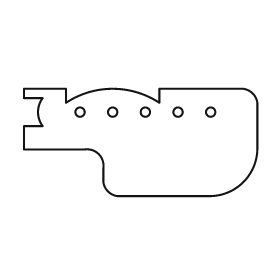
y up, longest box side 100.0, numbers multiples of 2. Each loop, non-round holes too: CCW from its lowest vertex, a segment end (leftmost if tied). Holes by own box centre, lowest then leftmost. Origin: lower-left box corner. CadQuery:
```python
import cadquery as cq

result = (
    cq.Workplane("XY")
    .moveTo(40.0, 0.0)
    .lineTo(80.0, 0.0)
    .threePointArc((94.0, 6.0), (100.0, 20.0))
    .lineTo(100.0, 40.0)
    .threePointArc((98.0, 44.0), (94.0, 46.0))
    .lineTo(58.0, 46.0)
    .lineTo(58.0, 40.0)
    .threePointArc((38.0, 46.0), (18.0, 40.0))
    .lineTo(18.0, 46.0)
    .lineTo(0.0, 46.0)
    .lineTo(0.0, 42.0)
    .lineTo(8.0, 42.0)
    .threePointArc((6.0, 36.0), (8.0, 30.0))
    .lineTo(0.0, 30.0)
    .lineTo(0.0, 20.0)
    .lineTo(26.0, 20.0)
    .threePointArc((32.0, 18.0), (34.0, 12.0))
    .lineTo(34.0, 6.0)
    .threePointArc((36.0, 2.0), (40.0, 0.0))
    .close()
    .moveTo(24.0, 36.0)
    .circle(2.0)
    .moveTo(38.0, 36.0)
    .circle(2.0)
    .moveTo(52.0, 36.0)
    .circle(2.0)
    .moveTo(66.0, 36.0)
    .circle(2.0)
    .moveTo(80.0, 36.0)
    .circle(2.0)
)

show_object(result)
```